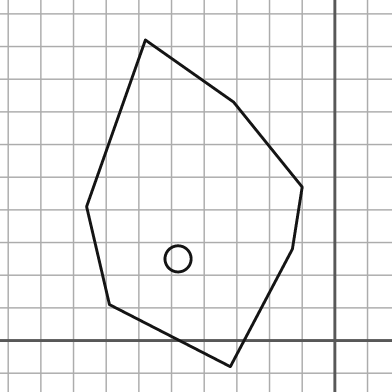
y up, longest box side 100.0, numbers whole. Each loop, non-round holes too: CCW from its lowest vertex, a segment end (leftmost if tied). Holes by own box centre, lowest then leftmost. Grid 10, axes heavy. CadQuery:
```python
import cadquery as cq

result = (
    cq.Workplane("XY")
    .moveTo(-32.0, -8.0)
    .lineTo(-13.0, 28.0)
    .lineTo(-10.0, 47.0)
    .lineTo(-31.0, 73.0)
    .lineTo(-58.0, 92.0)
    .lineTo(-76.0, 41.0)
    .lineTo(-69.0, 11.0)
    .close()
    .moveTo(-48.0, 25.0)
    .circle(4.0)
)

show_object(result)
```